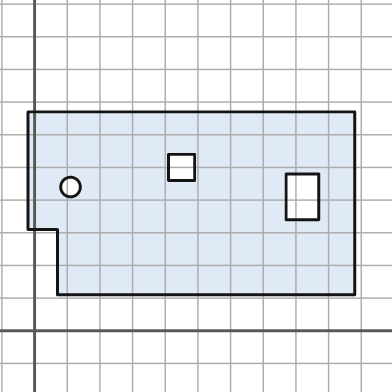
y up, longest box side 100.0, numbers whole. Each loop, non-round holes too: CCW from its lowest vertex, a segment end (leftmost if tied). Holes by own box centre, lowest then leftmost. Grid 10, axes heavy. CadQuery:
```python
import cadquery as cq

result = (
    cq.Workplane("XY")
    .moveTo(7.0, 11.0)
    .lineTo(98.0, 11.0)
    .lineTo(98.0, 67.0)
    .lineTo(-2.0, 67.0)
    .lineTo(-2.0, 31.0)
    .lineTo(7.0, 31.0)
    .close()
    .moveTo(77.0, 34.0)
    .lineTo(87.0, 34.0)
    .lineTo(87.0, 48.0)
    .lineTo(77.0, 48.0)
    .close()
    .moveTo(11.0, 44.0)
    .circle(3.0)
    .moveTo(41.0, 46.0)
    .lineTo(49.0, 46.0)
    .lineTo(49.0, 54.0)
    .lineTo(41.0, 54.0)
    .close()
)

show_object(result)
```